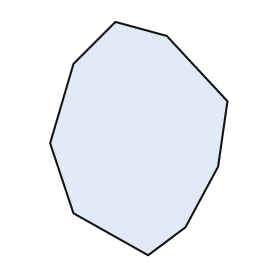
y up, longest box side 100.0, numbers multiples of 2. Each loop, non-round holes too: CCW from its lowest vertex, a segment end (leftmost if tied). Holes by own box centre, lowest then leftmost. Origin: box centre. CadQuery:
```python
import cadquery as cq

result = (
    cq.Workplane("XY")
    .moveTo(4.0, -50.0)
    .lineTo(20.0, -38.0)
    .lineTo(34.0, -12.0)
    .lineTo(38.0, 16.0)
    .lineTo(12.0, 44.0)
    .lineTo(-10.0, 50.0)
    .lineTo(-28.0, 32.0)
    .lineTo(-38.0, -2.0)
    .lineTo(-28.0, -32.0)
    .close()
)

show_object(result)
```